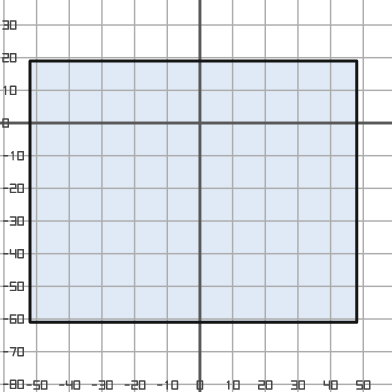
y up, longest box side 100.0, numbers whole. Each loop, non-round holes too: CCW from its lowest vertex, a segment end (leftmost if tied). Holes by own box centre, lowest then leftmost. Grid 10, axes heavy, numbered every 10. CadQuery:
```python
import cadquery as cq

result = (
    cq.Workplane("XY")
    .moveTo(-52.0, -61.0)
    .lineTo(48.0, -61.0)
    .lineTo(48.0, 19.0)
    .lineTo(-52.0, 19.0)
    .close()
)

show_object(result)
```